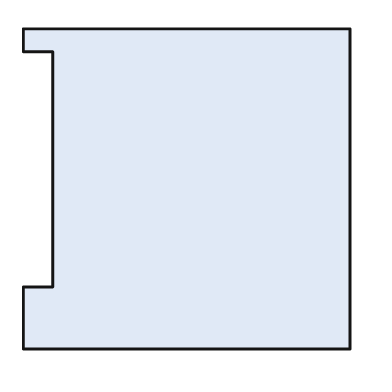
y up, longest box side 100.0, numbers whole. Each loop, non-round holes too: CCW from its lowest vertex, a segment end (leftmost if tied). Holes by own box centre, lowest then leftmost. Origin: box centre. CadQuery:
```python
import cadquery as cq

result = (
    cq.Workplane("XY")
    .moveTo(-50.0, -49.0)
    .lineTo(50.0, -49.0)
    .lineTo(50.0, 49.0)
    .lineTo(-50.0, 49.0)
    .lineTo(-50.0, 42.0)
    .lineTo(-41.0, 42.0)
    .lineTo(-41.0, -30.0)
    .lineTo(-50.0, -30.0)
    .close()
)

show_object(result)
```